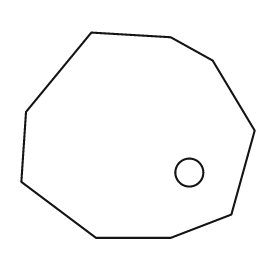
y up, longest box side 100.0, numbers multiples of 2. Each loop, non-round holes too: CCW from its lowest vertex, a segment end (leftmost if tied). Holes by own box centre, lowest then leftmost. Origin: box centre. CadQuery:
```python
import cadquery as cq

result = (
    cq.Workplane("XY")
    .moveTo(-18.0, -44.0)
    .lineTo(14.0, -44.0)
    .lineTo(40.0, -34.0)
    .lineTo(50.0, 2.0)
    .lineTo(32.0, 32.0)
    .lineTo(14.0, 42.0)
    .lineTo(-20.0, 44.0)
    .lineTo(-48.0, 10.0)
    .lineTo(-50.0, -20.0)
    .close()
    .moveTo(22.0, -16.0)
    .circle(6.0)
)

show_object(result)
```